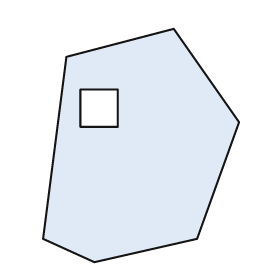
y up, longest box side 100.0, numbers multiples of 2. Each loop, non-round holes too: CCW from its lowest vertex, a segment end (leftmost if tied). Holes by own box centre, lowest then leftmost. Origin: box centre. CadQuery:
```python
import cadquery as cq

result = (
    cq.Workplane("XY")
    .moveTo(-20.0, -50.0)
    .lineTo(24.0, -40.0)
    .lineTo(42.0, 10.0)
    .lineTo(14.0, 50.0)
    .lineTo(-32.0, 38.0)
    .lineTo(-42.0, -40.0)
    .close()
    .moveTo(-26.0, 8.0)
    .lineTo(-10.0, 8.0)
    .lineTo(-10.0, 24.0)
    .lineTo(-26.0, 24.0)
    .close()
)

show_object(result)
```